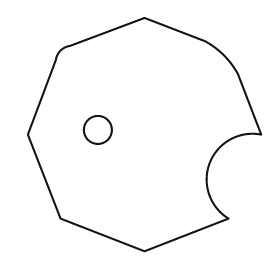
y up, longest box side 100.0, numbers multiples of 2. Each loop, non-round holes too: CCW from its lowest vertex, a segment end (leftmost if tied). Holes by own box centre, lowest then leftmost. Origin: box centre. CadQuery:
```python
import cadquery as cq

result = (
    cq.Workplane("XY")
    .moveTo(0.0, -50.0)
    .lineTo(36.0, -36.0)
    .threePointArc((28.0, -12.0), (50.0, 0.0))
    .lineTo(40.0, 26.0)
    .threePointArc((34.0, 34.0), (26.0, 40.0))
    .lineTo(0.0, 50.0)
    .lineTo(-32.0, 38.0)
    .threePointArc((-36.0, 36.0), (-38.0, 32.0))
    .lineTo(-50.0, 0.0)
    .lineTo(-36.0, -36.0)
    .close()
    .moveTo(-20.0, 2.0)
    .circle(6.0)
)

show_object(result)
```